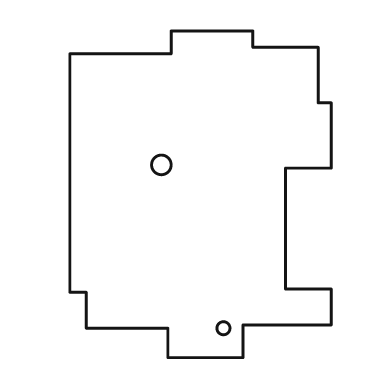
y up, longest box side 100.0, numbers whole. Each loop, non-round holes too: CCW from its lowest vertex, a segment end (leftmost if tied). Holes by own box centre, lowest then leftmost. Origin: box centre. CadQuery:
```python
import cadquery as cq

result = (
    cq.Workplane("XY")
    .moveTo(-10.0, -50.0)
    .lineTo(13.0, -50.0)
    .lineTo(13.0, -40.0)
    .lineTo(40.0, -40.0)
    .lineTo(40.0, -29.0)
    .lineTo(26.0, -29.0)
    .lineTo(26.0, 8.0)
    .lineTo(40.0, 8.0)
    .lineTo(40.0, 28.0)
    .lineTo(36.0, 28.0)
    .lineTo(36.0, 45.0)
    .lineTo(16.0, 45.0)
    .lineTo(16.0, 50.0)
    .lineTo(-9.0, 50.0)
    .lineTo(-9.0, 43.0)
    .lineTo(-40.0, 43.0)
    .lineTo(-40.0, -30.0)
    .lineTo(-35.0, -30.0)
    .lineTo(-35.0, -41.0)
    .lineTo(-10.0, -41.0)
    .close()
    .moveTo(7.0, -41.0)
    .circle(2.0)
    .moveTo(-12.0, 9.0)
    .circle(3.0)
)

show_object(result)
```